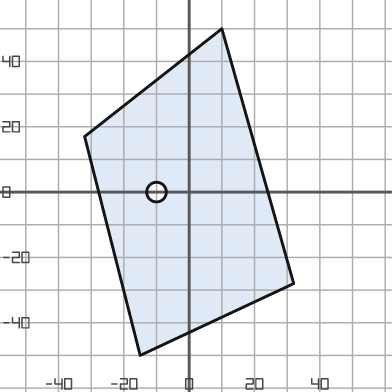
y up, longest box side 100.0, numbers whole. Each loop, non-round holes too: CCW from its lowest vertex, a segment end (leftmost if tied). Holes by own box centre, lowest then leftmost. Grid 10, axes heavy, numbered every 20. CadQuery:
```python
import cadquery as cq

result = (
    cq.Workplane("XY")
    .moveTo(-15.0, -50.0)
    .lineTo(32.0, -28.0)
    .lineTo(10.0, 50.0)
    .lineTo(-32.0, 17.0)
    .close()
    .moveTo(-10.0, 0.0)
    .circle(3.0)
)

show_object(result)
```